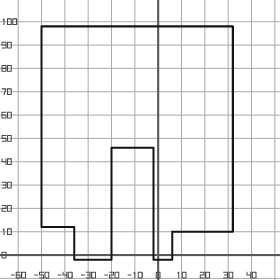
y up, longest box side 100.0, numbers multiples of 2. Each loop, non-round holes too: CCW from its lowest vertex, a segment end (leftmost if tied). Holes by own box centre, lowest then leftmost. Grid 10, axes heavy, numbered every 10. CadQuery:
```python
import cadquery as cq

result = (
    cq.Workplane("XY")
    .moveTo(-36.0, -2.0)
    .lineTo(-20.0, -2.0)
    .lineTo(-20.0, 46.0)
    .lineTo(-2.0, 46.0)
    .lineTo(-2.0, -2.0)
    .lineTo(6.0, -2.0)
    .lineTo(6.0, 10.0)
    .lineTo(32.0, 10.0)
    .lineTo(32.0, 98.0)
    .lineTo(-50.0, 98.0)
    .lineTo(-50.0, 12.0)
    .lineTo(-36.0, 12.0)
    .close()
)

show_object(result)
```